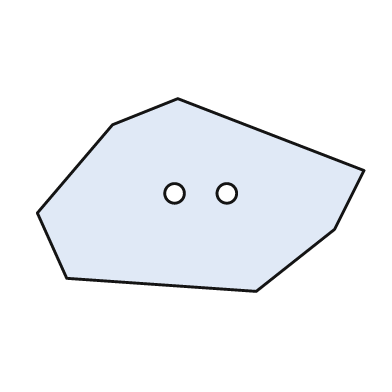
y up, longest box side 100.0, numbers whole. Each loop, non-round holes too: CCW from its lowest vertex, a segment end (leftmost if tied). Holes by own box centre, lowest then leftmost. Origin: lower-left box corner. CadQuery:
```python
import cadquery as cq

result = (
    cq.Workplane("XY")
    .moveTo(67.0, 0.0)
    .lineTo(91.0, 19.0)
    .lineTo(100.0, 37.0)
    .lineTo(43.0, 59.0)
    .lineTo(23.0, 51.0)
    .lineTo(0.0, 24.0)
    .lineTo(9.0, 4.0)
    .close()
    .moveTo(42.0, 30.0)
    .circle(3.0)
    .moveTo(58.0, 30.0)
    .circle(3.0)
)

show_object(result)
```